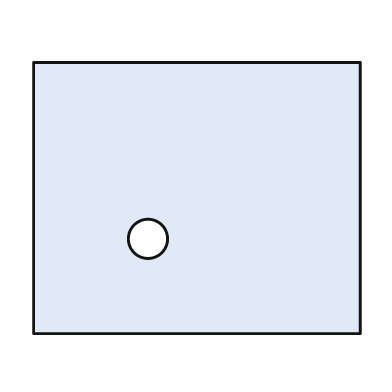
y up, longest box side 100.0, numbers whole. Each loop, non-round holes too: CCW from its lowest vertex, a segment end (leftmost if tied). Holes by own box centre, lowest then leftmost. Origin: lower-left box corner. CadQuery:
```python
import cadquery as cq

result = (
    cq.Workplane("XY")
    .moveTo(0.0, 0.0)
    .lineTo(100.0, 0.0)
    .lineTo(100.0, 83.0)
    .lineTo(0.0, 83.0)
    .close()
    .moveTo(35.0, 29.0)
    .circle(6.0)
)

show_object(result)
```